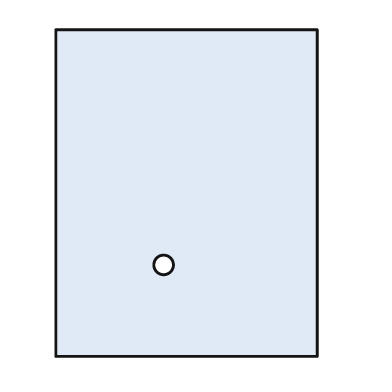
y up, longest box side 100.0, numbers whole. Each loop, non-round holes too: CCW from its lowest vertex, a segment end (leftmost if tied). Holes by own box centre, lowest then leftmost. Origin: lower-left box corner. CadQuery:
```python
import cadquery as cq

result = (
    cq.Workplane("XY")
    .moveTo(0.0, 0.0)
    .lineTo(80.0, 0.0)
    .lineTo(80.0, 100.0)
    .lineTo(0.0, 100.0)
    .close()
    .moveTo(33.0, 28.0)
    .circle(3.0)
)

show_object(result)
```